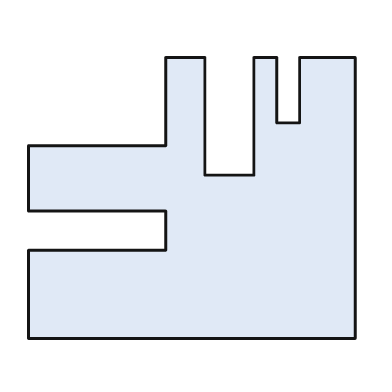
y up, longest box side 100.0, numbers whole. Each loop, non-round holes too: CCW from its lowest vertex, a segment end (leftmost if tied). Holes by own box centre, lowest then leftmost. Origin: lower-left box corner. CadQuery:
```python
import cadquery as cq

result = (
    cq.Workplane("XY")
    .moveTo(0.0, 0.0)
    .lineTo(100.0, 0.0)
    .lineTo(100.0, 86.0)
    .lineTo(83.0, 86.0)
    .lineTo(83.0, 66.0)
    .lineTo(76.0, 66.0)
    .lineTo(76.0, 86.0)
    .lineTo(69.0, 86.0)
    .lineTo(69.0, 50.0)
    .lineTo(54.0, 50.0)
    .lineTo(54.0, 86.0)
    .lineTo(42.0, 86.0)
    .lineTo(42.0, 59.0)
    .lineTo(0.0, 59.0)
    .lineTo(0.0, 39.0)
    .lineTo(42.0, 39.0)
    .lineTo(42.0, 27.0)
    .lineTo(0.0, 27.0)
    .close()
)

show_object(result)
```